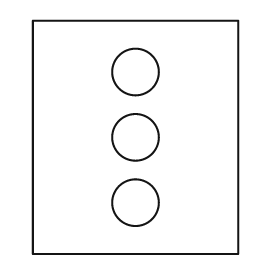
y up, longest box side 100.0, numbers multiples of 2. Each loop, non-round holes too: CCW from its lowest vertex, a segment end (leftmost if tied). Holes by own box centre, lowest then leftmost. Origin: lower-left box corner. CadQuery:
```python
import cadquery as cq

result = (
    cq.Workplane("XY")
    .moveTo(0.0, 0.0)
    .lineTo(88.0, 0.0)
    .lineTo(88.0, 100.0)
    .lineTo(0.0, 100.0)
    .close()
    .moveTo(44.0, 22.0)
    .circle(10.0)
    .moveTo(44.0, 50.0)
    .circle(10.0)
    .moveTo(44.0, 78.0)
    .circle(10.0)
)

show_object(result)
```